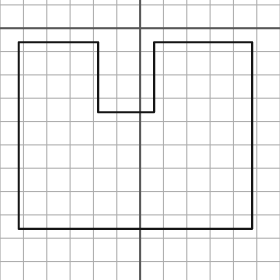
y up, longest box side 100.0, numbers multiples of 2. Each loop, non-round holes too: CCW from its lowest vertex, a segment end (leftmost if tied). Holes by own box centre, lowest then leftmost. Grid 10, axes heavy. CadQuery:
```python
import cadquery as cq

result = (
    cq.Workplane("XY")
    .moveTo(-52.0, -86.0)
    .lineTo(48.0, -86.0)
    .lineTo(48.0, -6.0)
    .lineTo(6.0, -6.0)
    .lineTo(6.0, -36.0)
    .lineTo(-18.0, -36.0)
    .lineTo(-18.0, -6.0)
    .lineTo(-52.0, -6.0)
    .close()
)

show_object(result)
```